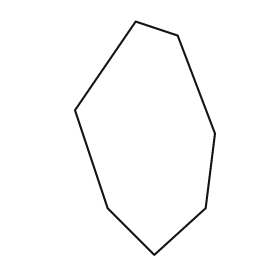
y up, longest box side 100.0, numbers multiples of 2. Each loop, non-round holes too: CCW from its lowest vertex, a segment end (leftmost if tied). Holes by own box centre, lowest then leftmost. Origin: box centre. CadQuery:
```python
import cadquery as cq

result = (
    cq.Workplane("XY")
    .moveTo(4.0, -50.0)
    .lineTo(26.0, -30.0)
    .lineTo(30.0, 2.0)
    .lineTo(14.0, 44.0)
    .lineTo(-4.0, 50.0)
    .lineTo(-30.0, 12.0)
    .lineTo(-16.0, -30.0)
    .close()
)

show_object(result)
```